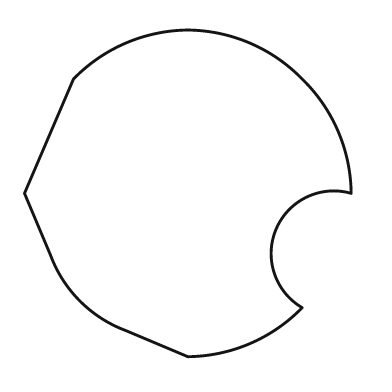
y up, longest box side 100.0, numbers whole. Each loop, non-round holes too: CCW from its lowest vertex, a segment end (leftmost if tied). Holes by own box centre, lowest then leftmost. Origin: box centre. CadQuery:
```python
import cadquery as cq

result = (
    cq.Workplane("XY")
    .moveTo(0.0, -50.0)
    .threePointArc((19.0, -46.0), (35.0, -35.0))
    .threePointArc((27.0, -11.0), (50.0, 0.0))
    .threePointArc((46.0, 19.0), (35.0, 35.0))
    .threePointArc((19.0, 46.0), (0.0, 50.0))
    .threePointArc((-19.0, 46.0), (-35.0, 35.0))
    .lineTo(-50.0, 0.0)
    .lineTo(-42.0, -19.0)
    .threePointArc((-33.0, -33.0), (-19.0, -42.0))
    .close()
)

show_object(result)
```